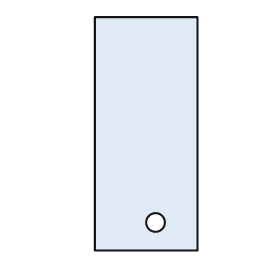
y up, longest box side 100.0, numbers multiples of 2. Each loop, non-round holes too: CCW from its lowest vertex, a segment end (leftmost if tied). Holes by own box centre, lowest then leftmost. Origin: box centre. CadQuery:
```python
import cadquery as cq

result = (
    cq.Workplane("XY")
    .moveTo(-22.0, -50.0)
    .lineTo(22.0, -50.0)
    .lineTo(22.0, 50.0)
    .lineTo(-22.0, 50.0)
    .close()
    .moveTo(4.0, -38.0)
    .circle(4.0)
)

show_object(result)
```